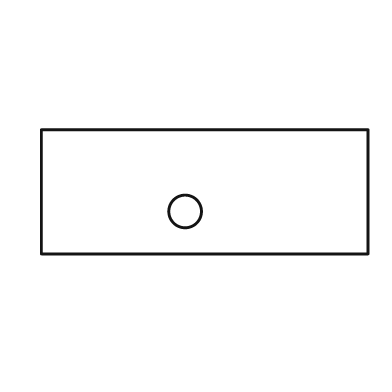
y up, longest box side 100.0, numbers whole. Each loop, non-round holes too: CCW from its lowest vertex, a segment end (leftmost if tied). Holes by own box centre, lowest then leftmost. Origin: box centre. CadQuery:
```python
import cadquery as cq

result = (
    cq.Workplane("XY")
    .moveTo(-50.0, -19.0)
    .lineTo(50.0, -19.0)
    .lineTo(50.0, 19.0)
    .lineTo(-50.0, 19.0)
    .close()
    .moveTo(-6.0, -6.0)
    .circle(5.0)
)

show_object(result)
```